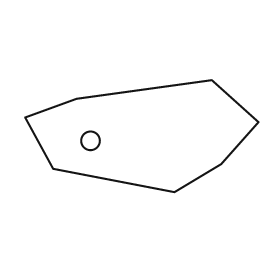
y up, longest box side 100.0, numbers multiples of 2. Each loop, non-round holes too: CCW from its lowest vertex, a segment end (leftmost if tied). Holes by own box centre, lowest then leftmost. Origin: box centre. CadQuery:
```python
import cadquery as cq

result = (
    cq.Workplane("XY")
    .moveTo(14.0, -24.0)
    .lineTo(34.0, -12.0)
    .lineTo(50.0, 6.0)
    .lineTo(30.0, 24.0)
    .lineTo(-28.0, 16.0)
    .lineTo(-50.0, 8.0)
    .lineTo(-38.0, -14.0)
    .close()
    .moveTo(-22.0, -2.0)
    .circle(4.0)
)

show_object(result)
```